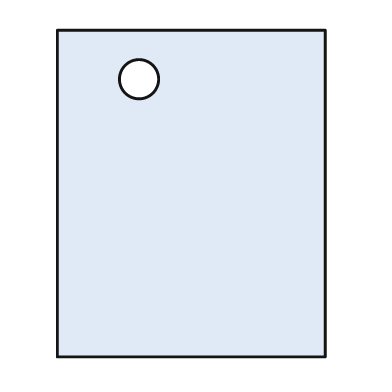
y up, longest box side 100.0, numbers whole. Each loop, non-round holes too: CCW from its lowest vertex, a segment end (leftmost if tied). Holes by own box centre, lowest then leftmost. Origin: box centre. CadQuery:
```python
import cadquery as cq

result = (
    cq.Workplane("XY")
    .moveTo(-41.0, -50.0)
    .lineTo(41.0, -50.0)
    .lineTo(41.0, 50.0)
    .lineTo(-41.0, 50.0)
    .close()
    .moveTo(-16.0, 35.0)
    .circle(6.0)
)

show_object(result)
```